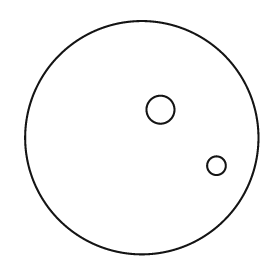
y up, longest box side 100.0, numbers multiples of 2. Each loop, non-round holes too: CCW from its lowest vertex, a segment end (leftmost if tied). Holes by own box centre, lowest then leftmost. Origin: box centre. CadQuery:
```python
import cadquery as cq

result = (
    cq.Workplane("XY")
    .moveTo(0.0, 0.0)
    .circle(50.0)
    .moveTo(32.0, -12.0)
    .circle(4.0)
    .moveTo(8.0, 12.0)
    .circle(6.0)
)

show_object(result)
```